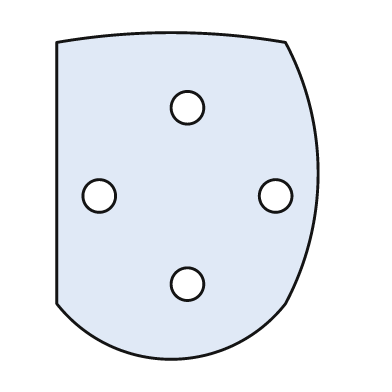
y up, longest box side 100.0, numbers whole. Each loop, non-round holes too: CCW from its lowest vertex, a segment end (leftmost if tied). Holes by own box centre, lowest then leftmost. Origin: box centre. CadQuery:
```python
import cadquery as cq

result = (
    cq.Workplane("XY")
    .moveTo(-40.0, -33.0)
    .threePointArc((-5.0, -50.0), (30.0, -33.0))
    .threePointArc((40.0, 7.0), (30.0, 47.0))
    .threePointArc((-5.0, 50.0), (-40.0, 47.0))
    .close()
    .moveTo(0.0, -27.0)
    .circle(5.0)
    .moveTo(-27.0, 0.0)
    .circle(5.0)
    .moveTo(27.0, 0.0)
    .circle(5.0)
    .moveTo(0.0, 27.0)
    .circle(5.0)
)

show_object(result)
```